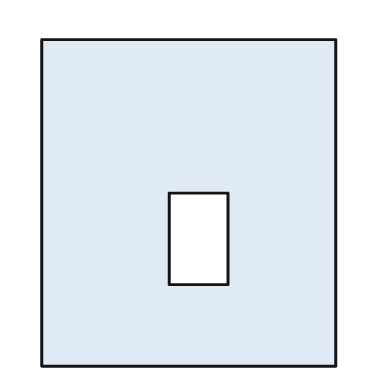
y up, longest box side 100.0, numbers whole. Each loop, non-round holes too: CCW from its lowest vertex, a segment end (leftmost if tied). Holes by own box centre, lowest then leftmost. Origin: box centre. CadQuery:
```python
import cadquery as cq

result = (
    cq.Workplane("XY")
    .moveTo(-45.0, -50.0)
    .lineTo(45.0, -50.0)
    .lineTo(45.0, 50.0)
    .lineTo(-45.0, 50.0)
    .close()
    .moveTo(-6.0, -25.0)
    .lineTo(12.0, -25.0)
    .lineTo(12.0, 3.0)
    .lineTo(-6.0, 3.0)
    .close()
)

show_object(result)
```